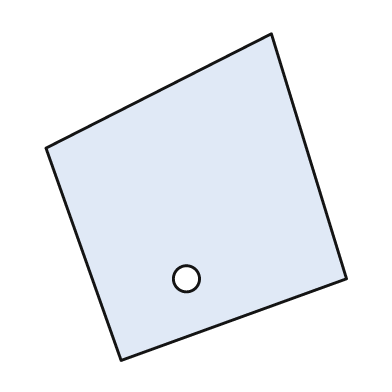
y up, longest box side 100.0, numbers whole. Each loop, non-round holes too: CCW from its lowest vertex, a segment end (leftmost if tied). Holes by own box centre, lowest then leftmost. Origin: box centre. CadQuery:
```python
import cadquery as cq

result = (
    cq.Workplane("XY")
    .moveTo(-23.0, -50.0)
    .lineTo(46.0, -25.0)
    .lineTo(23.0, 50.0)
    .lineTo(-46.0, 15.0)
    .close()
    .moveTo(-3.0, -25.0)
    .circle(4.0)
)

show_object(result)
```